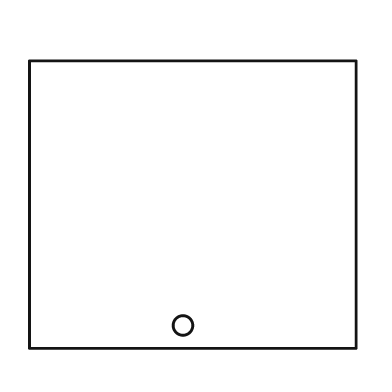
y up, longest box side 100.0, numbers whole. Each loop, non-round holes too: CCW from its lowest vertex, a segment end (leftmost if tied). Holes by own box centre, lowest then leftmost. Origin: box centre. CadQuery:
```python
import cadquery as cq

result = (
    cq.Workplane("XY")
    .moveTo(-50.0, -44.0)
    .lineTo(50.0, -44.0)
    .lineTo(50.0, 44.0)
    .lineTo(-50.0, 44.0)
    .close()
    .moveTo(-3.0, -37.0)
    .circle(3.0)
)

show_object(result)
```